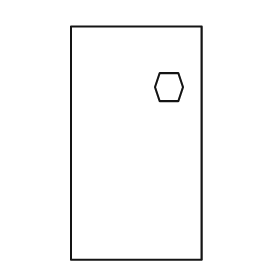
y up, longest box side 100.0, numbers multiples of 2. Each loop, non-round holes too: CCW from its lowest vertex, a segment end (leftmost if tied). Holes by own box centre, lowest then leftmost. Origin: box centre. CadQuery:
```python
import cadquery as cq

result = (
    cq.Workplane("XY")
    .moveTo(-28.0, -50.0)
    .lineTo(28.0, -50.0)
    .lineTo(28.0, 50.0)
    .lineTo(-28.0, 50.0)
    .close()
    .moveTo(10.0, 18.0)
    .lineTo(18.0, 18.0)
    .lineTo(20.0, 24.0)
    .lineTo(18.0, 30.0)
    .lineTo(10.0, 30.0)
    .lineTo(8.0, 24.0)
    .close()
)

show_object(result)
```